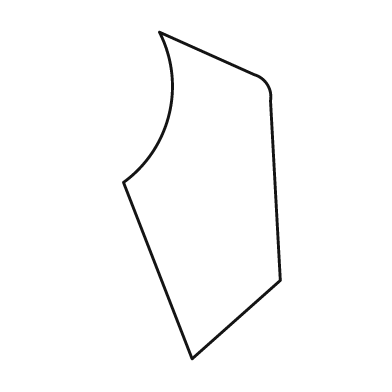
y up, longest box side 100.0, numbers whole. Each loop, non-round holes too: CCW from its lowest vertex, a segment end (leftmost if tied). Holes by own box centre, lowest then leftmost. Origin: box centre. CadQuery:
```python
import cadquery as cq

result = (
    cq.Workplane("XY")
    .moveTo(-3.0, -50.0)
    .lineTo(24.0, -26.0)
    .lineTo(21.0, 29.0)
    .threePointArc((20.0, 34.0), (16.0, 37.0))
    .lineTo(-13.0, 50.0)
    .threePointArc((-10.0, 25.0), (-24.0, 4.0))
    .close()
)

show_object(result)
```